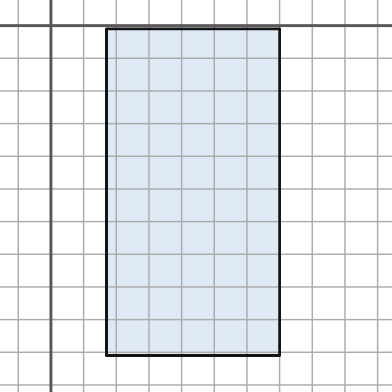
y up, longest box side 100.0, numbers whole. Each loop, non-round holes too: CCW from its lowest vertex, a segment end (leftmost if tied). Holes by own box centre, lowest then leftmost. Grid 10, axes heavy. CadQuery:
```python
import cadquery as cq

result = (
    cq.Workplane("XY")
    .moveTo(17.0, -101.0)
    .lineTo(70.0, -101.0)
    .lineTo(70.0, -1.0)
    .lineTo(17.0, -1.0)
    .close()
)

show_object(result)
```